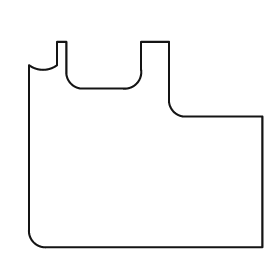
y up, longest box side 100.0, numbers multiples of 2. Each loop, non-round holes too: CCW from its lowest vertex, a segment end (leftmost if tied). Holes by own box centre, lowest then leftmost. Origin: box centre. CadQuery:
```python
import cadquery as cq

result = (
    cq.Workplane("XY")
    .moveTo(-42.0, -44.0)
    .lineTo(50.0, -44.0)
    .lineTo(50.0, 12.0)
    .lineTo(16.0, 12.0)
    .threePointArc((12.0, 14.0), (10.0, 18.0))
    .lineTo(10.0, 44.0)
    .lineTo(-2.0, 44.0)
    .lineTo(-2.0, 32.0)
    .threePointArc((-4.0, 26.0), (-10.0, 24.0))
    .lineTo(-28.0, 24.0)
    .threePointArc((-32.0, 26.0), (-34.0, 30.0))
    .lineTo(-34.0, 44.0)
    .lineTo(-38.0, 44.0)
    .lineTo(-38.0, 34.0)
    .threePointArc((-44.0, 32.0), (-50.0, 34.0))
    .lineTo(-50.0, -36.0)
    .threePointArc((-48.0, -42.0), (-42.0, -44.0))
    .close()
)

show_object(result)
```